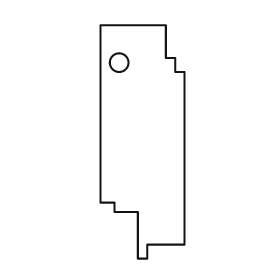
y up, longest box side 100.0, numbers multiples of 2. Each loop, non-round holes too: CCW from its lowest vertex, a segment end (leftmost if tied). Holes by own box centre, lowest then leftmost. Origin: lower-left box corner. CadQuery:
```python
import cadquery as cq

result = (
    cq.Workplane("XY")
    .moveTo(16.0, 0.0)
    .lineTo(20.0, 0.0)
    .lineTo(20.0, 6.0)
    .lineTo(36.0, 6.0)
    .lineTo(36.0, 80.0)
    .lineTo(32.0, 80.0)
    .lineTo(32.0, 86.0)
    .lineTo(28.0, 86.0)
    .lineTo(28.0, 100.0)
    .lineTo(0.0, 100.0)
    .lineTo(0.0, 24.0)
    .lineTo(6.0, 24.0)
    .lineTo(6.0, 20.0)
    .lineTo(16.0, 20.0)
    .close()
    .moveTo(8.0, 84.0)
    .circle(4.0)
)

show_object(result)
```